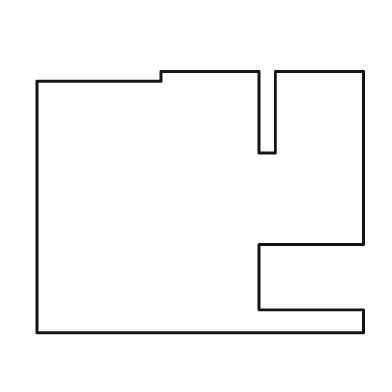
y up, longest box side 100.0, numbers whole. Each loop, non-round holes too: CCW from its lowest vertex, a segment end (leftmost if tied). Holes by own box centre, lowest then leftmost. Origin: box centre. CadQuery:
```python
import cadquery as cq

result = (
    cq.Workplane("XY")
    .moveTo(-50.0, -40.0)
    .lineTo(50.0, -40.0)
    .lineTo(50.0, -33.0)
    .lineTo(18.0, -33.0)
    .lineTo(18.0, -13.0)
    .lineTo(50.0, -13.0)
    .lineTo(50.0, 40.0)
    .lineTo(23.0, 40.0)
    .lineTo(23.0, 15.0)
    .lineTo(18.0, 15.0)
    .lineTo(18.0, 40.0)
    .lineTo(-12.0, 40.0)
    .lineTo(-12.0, 37.0)
    .lineTo(-50.0, 37.0)
    .close()
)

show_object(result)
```